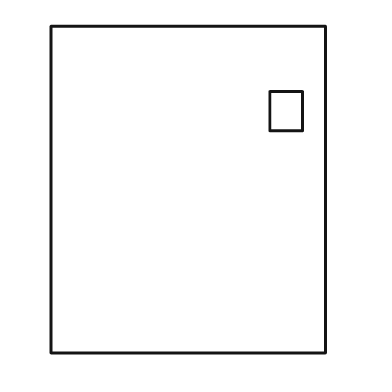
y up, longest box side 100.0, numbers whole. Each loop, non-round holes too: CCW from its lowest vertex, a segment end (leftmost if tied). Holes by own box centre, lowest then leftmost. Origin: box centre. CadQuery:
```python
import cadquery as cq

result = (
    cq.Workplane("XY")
    .moveTo(-42.0, -50.0)
    .lineTo(42.0, -50.0)
    .lineTo(42.0, 50.0)
    .lineTo(-42.0, 50.0)
    .close()
    .moveTo(25.0, 18.0)
    .lineTo(35.0, 18.0)
    .lineTo(35.0, 30.0)
    .lineTo(25.0, 30.0)
    .close()
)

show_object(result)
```